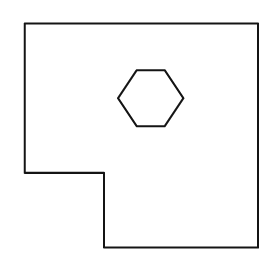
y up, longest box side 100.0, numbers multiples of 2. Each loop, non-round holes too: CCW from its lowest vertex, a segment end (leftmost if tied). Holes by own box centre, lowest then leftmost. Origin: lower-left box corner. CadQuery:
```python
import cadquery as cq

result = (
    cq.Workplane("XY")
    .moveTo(34.0, 0.0)
    .lineTo(100.0, 0.0)
    .lineTo(100.0, 96.0)
    .lineTo(0.0, 96.0)
    .lineTo(0.0, 32.0)
    .lineTo(34.0, 32.0)
    .close()
    .moveTo(48.0, 52.0)
    .lineTo(60.0, 52.0)
    .lineTo(68.0, 64.0)
    .lineTo(60.0, 76.0)
    .lineTo(48.0, 76.0)
    .lineTo(40.0, 64.0)
    .close()
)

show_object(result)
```